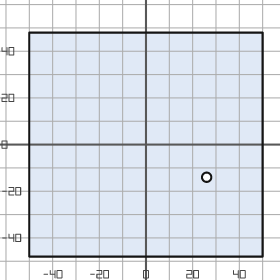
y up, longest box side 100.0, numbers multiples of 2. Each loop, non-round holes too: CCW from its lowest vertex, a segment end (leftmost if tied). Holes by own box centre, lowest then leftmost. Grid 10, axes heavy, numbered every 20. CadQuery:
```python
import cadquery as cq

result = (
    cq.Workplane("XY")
    .moveTo(-50.0, -48.0)
    .lineTo(50.0, -48.0)
    .lineTo(50.0, 48.0)
    .lineTo(-50.0, 48.0)
    .close()
    .moveTo(26.0, -14.0)
    .circle(2.0)
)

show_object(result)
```